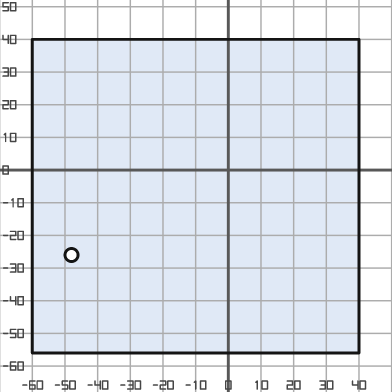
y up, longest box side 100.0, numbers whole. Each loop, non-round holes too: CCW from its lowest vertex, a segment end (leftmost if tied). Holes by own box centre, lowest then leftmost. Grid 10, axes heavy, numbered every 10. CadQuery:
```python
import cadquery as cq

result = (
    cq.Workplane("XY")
    .moveTo(-60.0, -56.0)
    .lineTo(40.0, -56.0)
    .lineTo(40.0, 40.0)
    .lineTo(-60.0, 40.0)
    .close()
    .moveTo(-48.0, -26.0)
    .circle(2.0)
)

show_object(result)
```